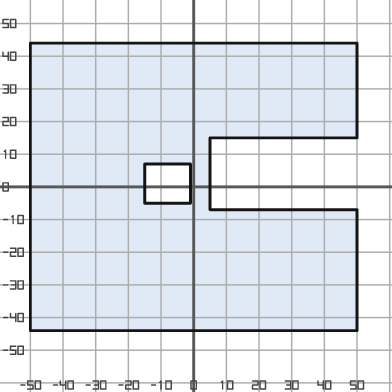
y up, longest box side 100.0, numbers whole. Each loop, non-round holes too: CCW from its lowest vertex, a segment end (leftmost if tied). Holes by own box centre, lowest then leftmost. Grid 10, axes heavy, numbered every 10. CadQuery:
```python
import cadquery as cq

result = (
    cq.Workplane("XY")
    .moveTo(-50.0, -44.0)
    .lineTo(50.0, -44.0)
    .lineTo(50.0, -7.0)
    .lineTo(5.0, -7.0)
    .lineTo(5.0, 15.0)
    .lineTo(50.0, 15.0)
    .lineTo(50.0, 44.0)
    .lineTo(-50.0, 44.0)
    .close()
    .moveTo(-15.0, -5.0)
    .lineTo(-1.0, -5.0)
    .lineTo(-1.0, 7.0)
    .lineTo(-15.0, 7.0)
    .close()
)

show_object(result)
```